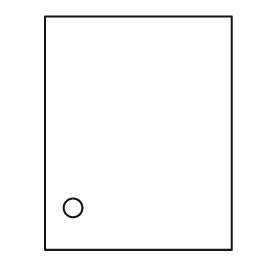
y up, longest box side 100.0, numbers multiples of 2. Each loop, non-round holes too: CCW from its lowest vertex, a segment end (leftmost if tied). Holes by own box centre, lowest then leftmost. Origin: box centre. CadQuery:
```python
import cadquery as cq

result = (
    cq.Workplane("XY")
    .moveTo(-40.0, -50.0)
    .lineTo(40.0, -50.0)
    .lineTo(40.0, 50.0)
    .lineTo(-40.0, 50.0)
    .close()
    .moveTo(-28.0, -32.0)
    .circle(4.0)
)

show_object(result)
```